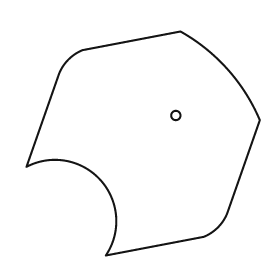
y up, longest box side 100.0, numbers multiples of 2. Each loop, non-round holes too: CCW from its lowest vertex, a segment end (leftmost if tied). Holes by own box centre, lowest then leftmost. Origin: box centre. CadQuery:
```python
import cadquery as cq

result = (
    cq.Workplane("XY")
    .moveTo(-16.0, -48.0)
    .lineTo(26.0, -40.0)
    .threePointArc((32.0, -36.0), (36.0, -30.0))
    .lineTo(50.0, 10.0)
    .threePointArc((36.0, 32.0), (16.0, 48.0))
    .lineTo(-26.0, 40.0)
    .threePointArc((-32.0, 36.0), (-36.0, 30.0))
    .lineTo(-50.0, -10.0)
    .threePointArc((-18.0, -16.0), (-16.0, -48.0))
    .close()
    .moveTo(14.0, 12.0)
    .circle(2.0)
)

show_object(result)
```